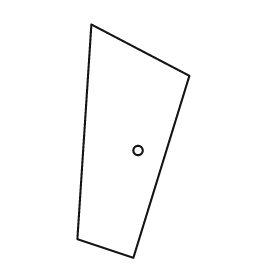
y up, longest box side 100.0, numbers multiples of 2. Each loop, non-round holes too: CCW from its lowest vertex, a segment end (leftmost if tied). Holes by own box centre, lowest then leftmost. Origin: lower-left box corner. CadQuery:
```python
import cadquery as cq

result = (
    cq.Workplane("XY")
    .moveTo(24.0, 0.0)
    .lineTo(48.0, 78.0)
    .lineTo(6.0, 100.0)
    .lineTo(0.0, 8.0)
    .close()
    .moveTo(26.0, 46.0)
    .circle(2.0)
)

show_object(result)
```